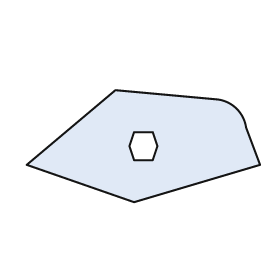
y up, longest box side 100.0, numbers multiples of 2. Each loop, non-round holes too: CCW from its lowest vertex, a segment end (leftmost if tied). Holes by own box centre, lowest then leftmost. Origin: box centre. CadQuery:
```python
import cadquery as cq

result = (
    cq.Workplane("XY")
    .moveTo(-4.0, -24.0)
    .lineTo(50.0, -8.0)
    .lineTo(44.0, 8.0)
    .threePointArc((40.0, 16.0), (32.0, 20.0))
    .lineTo(-12.0, 24.0)
    .lineTo(-50.0, -8.0)
    .close()
    .moveTo(-4.0, -6.0)
    .lineTo(4.0, -6.0)
    .lineTo(6.0, 0.0)
    .lineTo(4.0, 6.0)
    .lineTo(-4.0, 6.0)
    .lineTo(-6.0, 0.0)
    .close()
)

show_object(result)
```